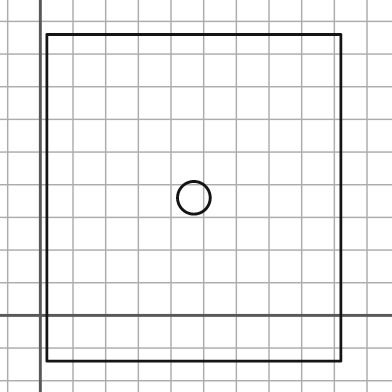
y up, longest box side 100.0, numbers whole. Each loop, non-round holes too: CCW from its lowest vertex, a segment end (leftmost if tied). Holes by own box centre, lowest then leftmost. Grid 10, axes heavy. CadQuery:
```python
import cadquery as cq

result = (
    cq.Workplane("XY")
    .moveTo(2.0, -14.0)
    .lineTo(92.0, -14.0)
    .lineTo(92.0, 86.0)
    .lineTo(2.0, 86.0)
    .close()
    .moveTo(47.0, 36.0)
    .circle(5.0)
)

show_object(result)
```